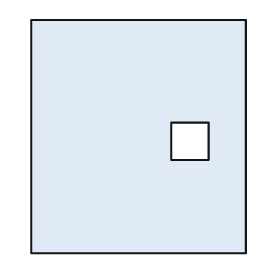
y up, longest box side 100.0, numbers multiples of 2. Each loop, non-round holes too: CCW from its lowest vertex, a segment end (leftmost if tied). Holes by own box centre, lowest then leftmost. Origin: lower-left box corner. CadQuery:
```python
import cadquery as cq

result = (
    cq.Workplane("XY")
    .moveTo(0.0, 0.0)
    .lineTo(92.0, 0.0)
    .lineTo(92.0, 100.0)
    .lineTo(0.0, 100.0)
    .close()
    .moveTo(60.0, 40.0)
    .lineTo(76.0, 40.0)
    .lineTo(76.0, 56.0)
    .lineTo(60.0, 56.0)
    .close()
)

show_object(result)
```